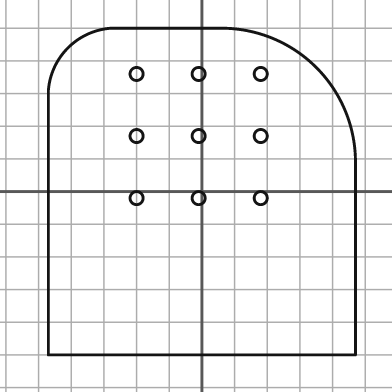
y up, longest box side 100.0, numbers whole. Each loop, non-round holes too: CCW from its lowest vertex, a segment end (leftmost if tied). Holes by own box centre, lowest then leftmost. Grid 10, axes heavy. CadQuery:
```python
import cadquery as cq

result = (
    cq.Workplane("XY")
    .moveTo(-47.0, -50.0)
    .lineTo(47.0, -50.0)
    .lineTo(47.0, 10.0)
    .threePointArc((35.0, 38.0), (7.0, 50.0))
    .lineTo(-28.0, 50.0)
    .threePointArc((-41.0, 44.0), (-47.0, 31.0))
    .close()
    .moveTo(-20.0, -2.0)
    .circle(2.0)
    .moveTo(-1.0, -2.0)
    .circle(2.0)
    .moveTo(18.0, -2.0)
    .circle(2.0)
    .moveTo(-20.0, 17.0)
    .circle(2.0)
    .moveTo(-1.0, 17.0)
    .circle(2.0)
    .moveTo(18.0, 17.0)
    .circle(2.0)
    .moveTo(-20.0, 36.0)
    .circle(2.0)
    .moveTo(-1.0, 36.0)
    .circle(2.0)
    .moveTo(18.0, 36.0)
    .circle(2.0)
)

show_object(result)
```